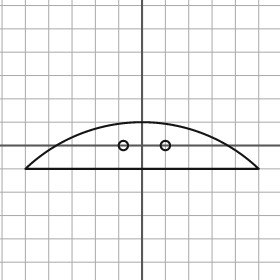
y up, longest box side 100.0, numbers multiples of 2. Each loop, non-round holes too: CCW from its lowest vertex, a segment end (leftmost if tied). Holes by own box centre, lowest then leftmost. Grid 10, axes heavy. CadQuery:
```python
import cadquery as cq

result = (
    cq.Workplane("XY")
    .moveTo(-50.0, -10.0)
    .lineTo(50.0, -10.0)
    .threePointArc((0.0, 10.0), (-50.0, -10.0))
    .close()
    .moveTo(-8.0, 0.0)
    .circle(2.0)
    .moveTo(10.0, 0.0)
    .circle(2.0)
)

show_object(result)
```